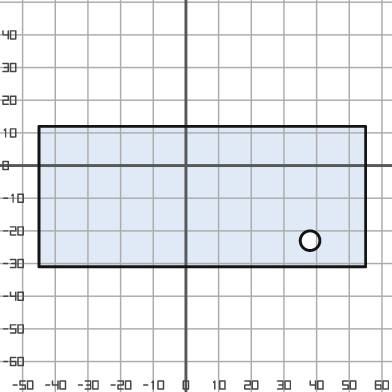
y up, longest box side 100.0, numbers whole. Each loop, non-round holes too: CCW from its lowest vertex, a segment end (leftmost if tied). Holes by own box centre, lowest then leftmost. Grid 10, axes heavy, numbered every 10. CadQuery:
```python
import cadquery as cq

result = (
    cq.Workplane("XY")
    .moveTo(-45.0, -31.0)
    .lineTo(55.0, -31.0)
    .lineTo(55.0, 12.0)
    .lineTo(-45.0, 12.0)
    .close()
    .moveTo(38.0, -23.0)
    .circle(3.0)
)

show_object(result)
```